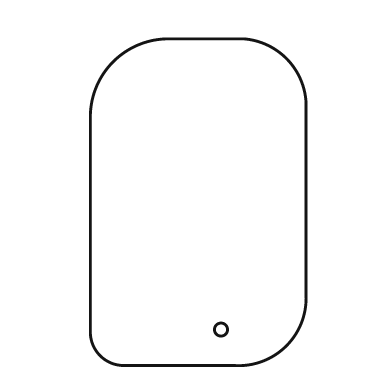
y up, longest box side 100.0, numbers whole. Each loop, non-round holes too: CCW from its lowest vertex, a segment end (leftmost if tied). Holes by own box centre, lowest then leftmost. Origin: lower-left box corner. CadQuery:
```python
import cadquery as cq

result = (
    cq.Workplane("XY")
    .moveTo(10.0, 0.0)
    .lineTo(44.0, 0.0)
    .threePointArc((60.0, 6.0), (66.0, 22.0))
    .lineTo(66.0, 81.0)
    .threePointArc((60.0, 94.0), (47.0, 100.0))
    .lineTo(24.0, 100.0)
    .threePointArc((7.0, 93.0), (0.0, 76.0))
    .lineTo(0.0, 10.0)
    .threePointArc((3.0, 3.0), (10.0, 0.0))
    .close()
    .moveTo(40.0, 11.0)
    .circle(2.0)
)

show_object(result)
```